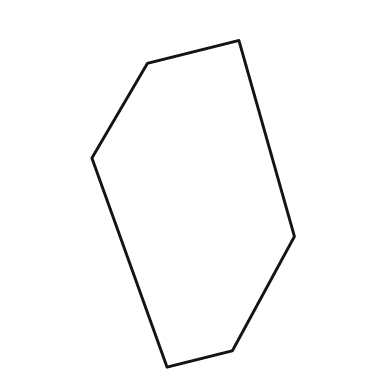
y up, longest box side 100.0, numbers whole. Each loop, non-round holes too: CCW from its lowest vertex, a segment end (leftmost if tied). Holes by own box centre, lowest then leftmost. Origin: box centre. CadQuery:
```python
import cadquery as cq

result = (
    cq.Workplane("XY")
    .moveTo(-8.0, -50.0)
    .lineTo(12.0, -45.0)
    .lineTo(31.0, -10.0)
    .lineTo(14.0, 50.0)
    .lineTo(-14.0, 43.0)
    .lineTo(-31.0, 14.0)
    .close()
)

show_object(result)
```